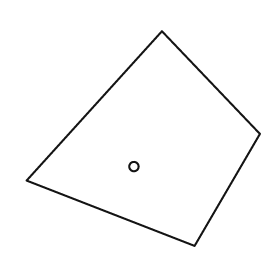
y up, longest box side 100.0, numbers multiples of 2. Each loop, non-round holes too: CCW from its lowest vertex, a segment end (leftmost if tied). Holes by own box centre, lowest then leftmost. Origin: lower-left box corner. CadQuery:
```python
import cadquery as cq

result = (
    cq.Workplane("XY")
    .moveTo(72.0, 0.0)
    .lineTo(100.0, 48.0)
    .lineTo(58.0, 92.0)
    .lineTo(0.0, 28.0)
    .close()
    .moveTo(46.0, 34.0)
    .circle(2.0)
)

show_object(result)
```